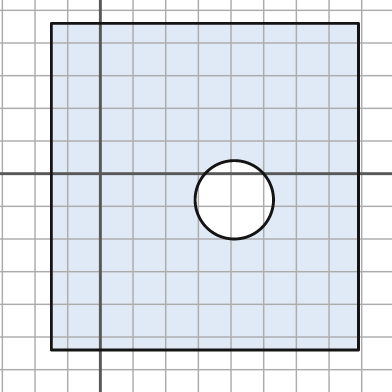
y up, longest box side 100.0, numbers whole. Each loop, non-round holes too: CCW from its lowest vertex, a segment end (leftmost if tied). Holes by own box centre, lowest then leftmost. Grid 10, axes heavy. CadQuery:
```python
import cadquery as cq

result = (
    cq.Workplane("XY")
    .moveTo(-15.0, -54.0)
    .lineTo(79.0, -54.0)
    .lineTo(79.0, 46.0)
    .lineTo(-15.0, 46.0)
    .close()
    .moveTo(41.0, -8.0)
    .circle(12.0)
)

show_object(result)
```